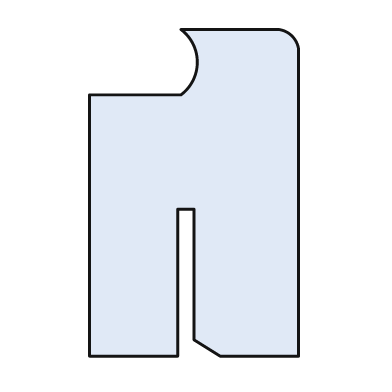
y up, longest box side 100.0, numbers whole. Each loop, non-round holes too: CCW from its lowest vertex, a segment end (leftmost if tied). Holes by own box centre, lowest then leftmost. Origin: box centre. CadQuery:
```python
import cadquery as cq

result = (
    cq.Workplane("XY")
    .moveTo(-32.0, -50.0)
    .lineTo(-5.0, -50.0)
    .lineTo(-5.0, -5.0)
    .lineTo(0.0, -5.0)
    .lineTo(0.0, -45.0)
    .lineTo(8.0, -50.0)
    .lineTo(32.0, -50.0)
    .lineTo(32.0, 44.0)
    .threePointArc((30.0, 48.0), (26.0, 50.0))
    .lineTo(-4.0, 50.0)
    .threePointArc((1.0, 40.0), (-4.0, 30.0))
    .lineTo(-32.0, 30.0)
    .close()
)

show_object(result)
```